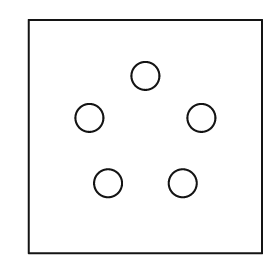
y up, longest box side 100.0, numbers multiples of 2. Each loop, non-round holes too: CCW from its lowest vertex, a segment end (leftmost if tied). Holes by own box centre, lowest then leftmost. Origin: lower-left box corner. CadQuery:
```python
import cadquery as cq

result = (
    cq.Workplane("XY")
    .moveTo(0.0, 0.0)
    .lineTo(100.0, 0.0)
    .lineTo(100.0, 100.0)
    .lineTo(0.0, 100.0)
    .close()
    .moveTo(34.0, 30.0)
    .circle(6.0)
    .moveTo(66.0, 30.0)
    .circle(6.0)
    .moveTo(26.0, 58.0)
    .circle(6.0)
    .moveTo(74.0, 58.0)
    .circle(6.0)
    .moveTo(50.0, 76.0)
    .circle(6.0)
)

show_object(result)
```